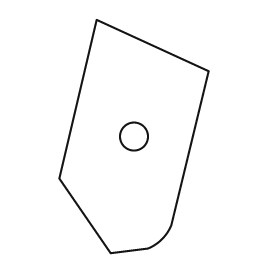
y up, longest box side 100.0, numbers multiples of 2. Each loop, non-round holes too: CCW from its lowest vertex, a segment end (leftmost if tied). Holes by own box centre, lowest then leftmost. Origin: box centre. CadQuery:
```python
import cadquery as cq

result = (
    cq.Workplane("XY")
    .moveTo(-10.0, -50.0)
    .lineTo(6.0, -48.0)
    .threePointArc((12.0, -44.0), (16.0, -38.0))
    .lineTo(32.0, 28.0)
    .lineTo(-16.0, 50.0)
    .lineTo(-32.0, -18.0)
    .close()
    .moveTo(0.0, 0.0)
    .circle(6.0)
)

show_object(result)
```